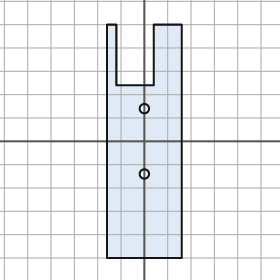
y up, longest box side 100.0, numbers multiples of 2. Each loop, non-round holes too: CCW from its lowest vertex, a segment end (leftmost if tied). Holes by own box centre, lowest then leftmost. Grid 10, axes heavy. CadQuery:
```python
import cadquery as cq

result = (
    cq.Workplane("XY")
    .moveTo(-16.0, -50.0)
    .lineTo(16.0, -50.0)
    .lineTo(16.0, 50.0)
    .lineTo(4.0, 50.0)
    .lineTo(4.0, 24.0)
    .lineTo(-12.0, 24.0)
    .lineTo(-12.0, 50.0)
    .lineTo(-16.0, 50.0)
    .close()
    .moveTo(0.0, -14.0)
    .circle(2.0)
    .moveTo(0.0, 14.0)
    .circle(2.0)
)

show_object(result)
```